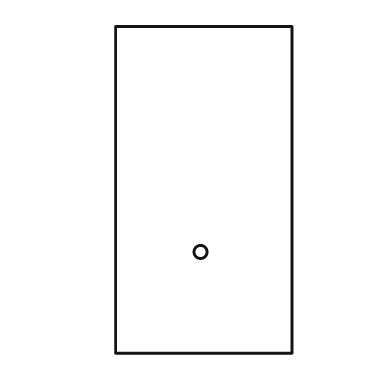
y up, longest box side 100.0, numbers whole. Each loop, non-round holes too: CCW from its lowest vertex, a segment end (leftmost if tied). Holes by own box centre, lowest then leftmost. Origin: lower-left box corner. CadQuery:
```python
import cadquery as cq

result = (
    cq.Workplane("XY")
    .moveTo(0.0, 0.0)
    .lineTo(54.0, 0.0)
    .lineTo(54.0, 100.0)
    .lineTo(0.0, 100.0)
    .close()
    .moveTo(26.0, 31.0)
    .circle(2.0)
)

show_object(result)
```